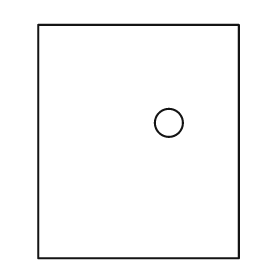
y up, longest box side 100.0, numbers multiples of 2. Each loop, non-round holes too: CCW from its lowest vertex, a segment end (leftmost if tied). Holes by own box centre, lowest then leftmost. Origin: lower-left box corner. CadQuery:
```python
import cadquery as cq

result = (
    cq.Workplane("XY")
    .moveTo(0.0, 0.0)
    .lineTo(86.0, 0.0)
    .lineTo(86.0, 100.0)
    .lineTo(0.0, 100.0)
    .close()
    .moveTo(56.0, 58.0)
    .circle(6.0)
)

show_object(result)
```